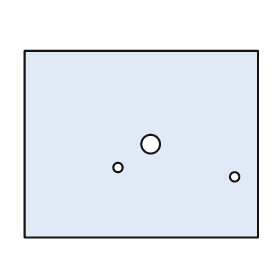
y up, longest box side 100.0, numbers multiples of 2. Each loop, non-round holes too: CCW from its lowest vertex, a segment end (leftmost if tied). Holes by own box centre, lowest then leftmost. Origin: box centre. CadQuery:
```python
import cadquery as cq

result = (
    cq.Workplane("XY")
    .moveTo(-50.0, -40.0)
    .lineTo(50.0, -40.0)
    .lineTo(50.0, 40.0)
    .lineTo(-50.0, 40.0)
    .close()
    .moveTo(40.0, -14.0)
    .circle(2.0)
    .moveTo(-10.0, -10.0)
    .circle(2.0)
    .moveTo(4.0, 0.0)
    .circle(4.0)
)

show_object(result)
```